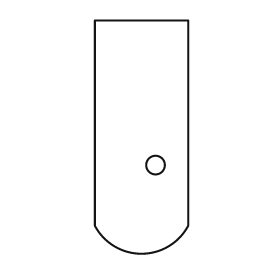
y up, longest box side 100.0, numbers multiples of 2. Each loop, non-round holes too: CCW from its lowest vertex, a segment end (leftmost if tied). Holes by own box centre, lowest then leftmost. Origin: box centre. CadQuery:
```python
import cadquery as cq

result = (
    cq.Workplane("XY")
    .moveTo(-20.0, -38.0)
    .threePointArc((0.0, -50.0), (20.0, -38.0))
    .lineTo(20.0, 50.0)
    .lineTo(-20.0, 50.0)
    .close()
    .moveTo(6.0, -12.0)
    .circle(4.0)
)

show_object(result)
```